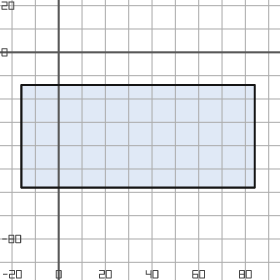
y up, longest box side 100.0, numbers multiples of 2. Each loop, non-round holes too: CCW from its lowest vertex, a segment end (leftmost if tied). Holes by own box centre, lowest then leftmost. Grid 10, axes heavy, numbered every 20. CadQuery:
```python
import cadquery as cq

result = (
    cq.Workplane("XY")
    .moveTo(-16.0, -58.0)
    .lineTo(84.0, -58.0)
    .lineTo(84.0, -14.0)
    .lineTo(-16.0, -14.0)
    .close()
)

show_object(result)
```